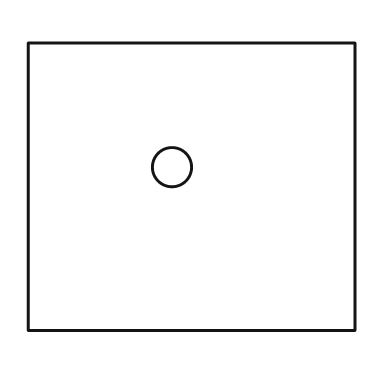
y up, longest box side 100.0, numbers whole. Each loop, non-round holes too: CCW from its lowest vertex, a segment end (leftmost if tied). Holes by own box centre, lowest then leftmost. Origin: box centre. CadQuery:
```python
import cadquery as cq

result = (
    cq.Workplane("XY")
    .moveTo(-50.0, -44.0)
    .lineTo(50.0, -44.0)
    .lineTo(50.0, 44.0)
    .lineTo(-50.0, 44.0)
    .close()
    .moveTo(-6.0, 6.0)
    .circle(6.0)
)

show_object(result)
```